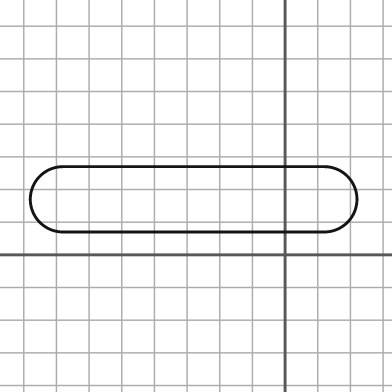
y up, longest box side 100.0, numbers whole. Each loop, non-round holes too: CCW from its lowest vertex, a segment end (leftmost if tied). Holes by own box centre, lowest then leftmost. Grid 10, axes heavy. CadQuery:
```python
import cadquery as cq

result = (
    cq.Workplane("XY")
    .moveTo(-68.0, 7.0)
    .lineTo(12.0, 7.0)
    .threePointArc((22.0, 17.0), (12.0, 27.0))
    .lineTo(-68.0, 27.0)
    .threePointArc((-78.0, 17.0), (-68.0, 7.0))
    .close()
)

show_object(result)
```